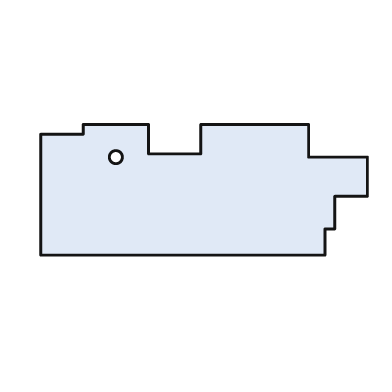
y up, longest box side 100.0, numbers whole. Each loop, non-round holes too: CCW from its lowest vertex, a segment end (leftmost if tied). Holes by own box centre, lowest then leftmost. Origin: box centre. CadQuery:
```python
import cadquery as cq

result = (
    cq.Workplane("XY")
    .moveTo(-50.0, -20.0)
    .lineTo(37.0, -20.0)
    .lineTo(37.0, -12.0)
    .lineTo(40.0, -12.0)
    .lineTo(40.0, -2.0)
    .lineTo(50.0, -2.0)
    .lineTo(50.0, 10.0)
    .lineTo(32.0, 10.0)
    .lineTo(32.0, 20.0)
    .lineTo(-1.0, 20.0)
    .lineTo(-1.0, 11.0)
    .lineTo(-17.0, 11.0)
    .lineTo(-17.0, 20.0)
    .lineTo(-37.0, 20.0)
    .lineTo(-37.0, 17.0)
    .lineTo(-50.0, 17.0)
    .close()
    .moveTo(-27.0, 10.0)
    .circle(2.0)
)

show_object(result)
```